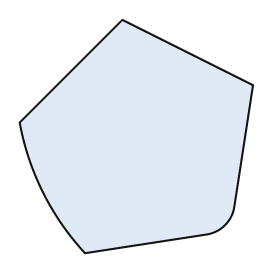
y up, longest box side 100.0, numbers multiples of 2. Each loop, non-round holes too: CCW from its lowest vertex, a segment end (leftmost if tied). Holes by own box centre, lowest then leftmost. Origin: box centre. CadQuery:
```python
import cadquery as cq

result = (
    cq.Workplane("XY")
    .moveTo(-22.0, -50.0)
    .lineTo(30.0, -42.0)
    .threePointArc((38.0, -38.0), (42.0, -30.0))
    .lineTo(50.0, 22.0)
    .lineTo(-6.0, 50.0)
    .lineTo(-50.0, 6.0)
    .threePointArc((-40.0, -24.0), (-22.0, -50.0))
    .close()
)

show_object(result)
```